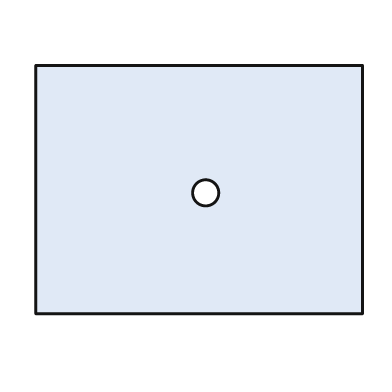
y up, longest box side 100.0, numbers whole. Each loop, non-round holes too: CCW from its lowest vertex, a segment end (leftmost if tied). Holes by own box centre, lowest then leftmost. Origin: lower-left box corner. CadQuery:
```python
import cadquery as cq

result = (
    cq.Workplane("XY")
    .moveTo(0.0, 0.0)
    .lineTo(100.0, 0.0)
    .lineTo(100.0, 76.0)
    .lineTo(0.0, 76.0)
    .close()
    .moveTo(52.0, 37.0)
    .circle(4.0)
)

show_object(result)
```